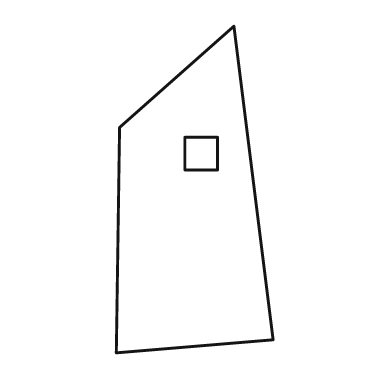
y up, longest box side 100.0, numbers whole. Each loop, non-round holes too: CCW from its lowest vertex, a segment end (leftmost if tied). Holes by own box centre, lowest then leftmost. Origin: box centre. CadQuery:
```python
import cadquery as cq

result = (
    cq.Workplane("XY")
    .moveTo(-24.0, -50.0)
    .lineTo(24.0, -46.0)
    .lineTo(12.0, 50.0)
    .lineTo(-23.0, 19.0)
    .close()
    .moveTo(-3.0, 6.0)
    .lineTo(7.0, 6.0)
    .lineTo(7.0, 16.0)
    .lineTo(-3.0, 16.0)
    .close()
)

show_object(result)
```